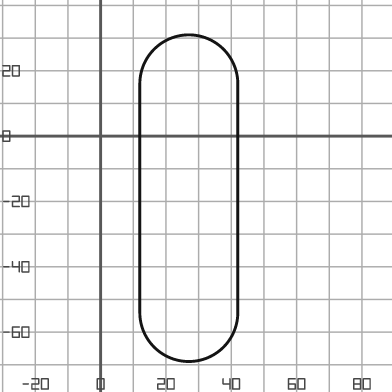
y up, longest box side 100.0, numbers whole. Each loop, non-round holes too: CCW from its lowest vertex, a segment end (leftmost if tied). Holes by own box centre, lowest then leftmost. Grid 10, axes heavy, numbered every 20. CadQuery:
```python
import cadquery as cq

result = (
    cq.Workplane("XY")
    .moveTo(12.0, -54.0)
    .threePointArc((27.0, -69.0), (42.0, -54.0))
    .lineTo(42.0, 16.0)
    .threePointArc((27.0, 31.0), (12.0, 16.0))
    .close()
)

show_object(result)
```